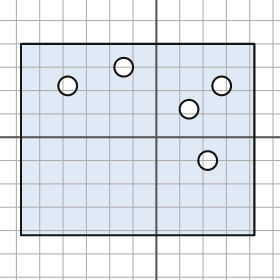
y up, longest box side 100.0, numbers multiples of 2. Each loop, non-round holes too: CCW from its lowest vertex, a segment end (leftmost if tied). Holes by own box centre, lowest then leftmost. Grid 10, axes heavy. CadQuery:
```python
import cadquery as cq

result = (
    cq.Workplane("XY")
    .moveTo(-58.0, -42.0)
    .lineTo(42.0, -42.0)
    .lineTo(42.0, 40.0)
    .lineTo(-58.0, 40.0)
    .close()
    .moveTo(22.0, -10.0)
    .circle(4.0)
    .moveTo(14.0, 12.0)
    .circle(4.0)
    .moveTo(-38.0, 22.0)
    .circle(4.0)
    .moveTo(28.0, 22.0)
    .circle(4.0)
    .moveTo(-14.0, 30.0)
    .circle(4.0)
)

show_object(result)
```